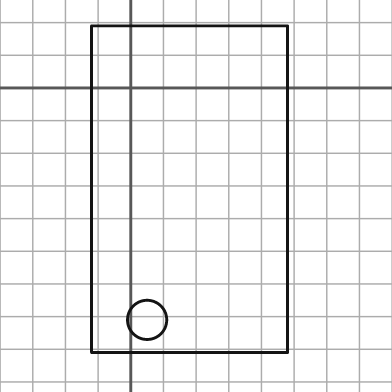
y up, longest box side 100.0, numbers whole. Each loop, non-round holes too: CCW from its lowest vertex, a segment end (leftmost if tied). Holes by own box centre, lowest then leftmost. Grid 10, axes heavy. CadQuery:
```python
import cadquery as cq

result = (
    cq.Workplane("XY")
    .moveTo(-12.0, -81.0)
    .lineTo(48.0, -81.0)
    .lineTo(48.0, 19.0)
    .lineTo(-12.0, 19.0)
    .close()
    .moveTo(5.0, -71.0)
    .circle(6.0)
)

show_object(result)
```